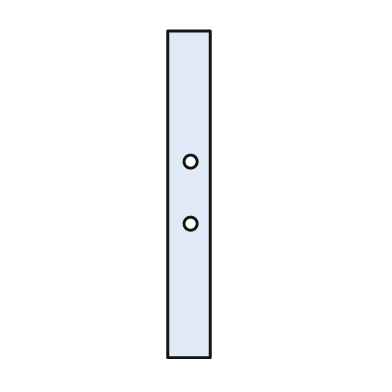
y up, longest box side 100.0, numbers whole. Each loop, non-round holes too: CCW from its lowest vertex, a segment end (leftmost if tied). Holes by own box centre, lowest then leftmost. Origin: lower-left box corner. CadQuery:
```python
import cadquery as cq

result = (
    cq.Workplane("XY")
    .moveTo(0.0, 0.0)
    .lineTo(13.0, 0.0)
    .lineTo(13.0, 100.0)
    .lineTo(0.0, 100.0)
    .close()
    .moveTo(7.0, 41.0)
    .circle(2.0)
    .moveTo(7.0, 60.0)
    .circle(2.0)
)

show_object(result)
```